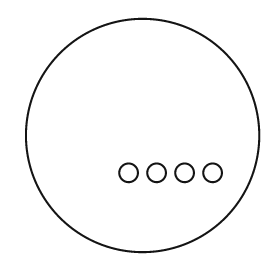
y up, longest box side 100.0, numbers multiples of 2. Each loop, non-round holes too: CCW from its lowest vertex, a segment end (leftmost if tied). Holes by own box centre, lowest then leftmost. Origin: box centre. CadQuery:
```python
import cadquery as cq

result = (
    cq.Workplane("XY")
    .moveTo(0.0, 0.0)
    .circle(50.0)
    .moveTo(-6.0, -16.0)
    .circle(4.0)
    .moveTo(6.0, -16.0)
    .circle(4.0)
    .moveTo(18.0, -16.0)
    .circle(4.0)
    .moveTo(30.0, -16.0)
    .circle(4.0)
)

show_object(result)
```